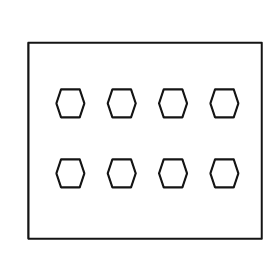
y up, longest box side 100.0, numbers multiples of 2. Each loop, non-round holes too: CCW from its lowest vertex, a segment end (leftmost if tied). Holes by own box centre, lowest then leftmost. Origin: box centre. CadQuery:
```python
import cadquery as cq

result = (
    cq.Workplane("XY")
    .moveTo(-50.0, -42.0)
    .lineTo(50.0, -42.0)
    .lineTo(50.0, 42.0)
    .lineTo(-50.0, 42.0)
    .close()
    .moveTo(-36.0, -20.0)
    .lineTo(-28.0, -20.0)
    .lineTo(-26.0, -14.0)
    .lineTo(-28.0, -8.0)
    .lineTo(-36.0, -8.0)
    .lineTo(-38.0, -14.0)
    .close()
    .moveTo(-14.0, -20.0)
    .lineTo(-6.0, -20.0)
    .lineTo(-4.0, -14.0)
    .lineTo(-6.0, -8.0)
    .lineTo(-14.0, -8.0)
    .lineTo(-16.0, -14.0)
    .close()
    .moveTo(8.0, -20.0)
    .lineTo(16.0, -20.0)
    .lineTo(18.0, -14.0)
    .lineTo(16.0, -8.0)
    .lineTo(8.0, -8.0)
    .lineTo(6.0, -14.0)
    .close()
    .moveTo(30.0, -20.0)
    .lineTo(38.0, -20.0)
    .lineTo(40.0, -14.0)
    .lineTo(38.0, -8.0)
    .lineTo(30.0, -8.0)
    .lineTo(28.0, -14.0)
    .close()
    .moveTo(-36.0, 10.0)
    .lineTo(-28.0, 10.0)
    .lineTo(-26.0, 16.0)
    .lineTo(-28.0, 22.0)
    .lineTo(-36.0, 22.0)
    .lineTo(-38.0, 16.0)
    .close()
    .moveTo(-14.0, 10.0)
    .lineTo(-6.0, 10.0)
    .lineTo(-4.0, 16.0)
    .lineTo(-6.0, 22.0)
    .lineTo(-14.0, 22.0)
    .lineTo(-16.0, 16.0)
    .close()
    .moveTo(8.0, 10.0)
    .lineTo(16.0, 10.0)
    .lineTo(18.0, 16.0)
    .lineTo(16.0, 22.0)
    .lineTo(8.0, 22.0)
    .lineTo(6.0, 16.0)
    .close()
    .moveTo(30.0, 10.0)
    .lineTo(38.0, 10.0)
    .lineTo(40.0, 16.0)
    .lineTo(38.0, 22.0)
    .lineTo(30.0, 22.0)
    .lineTo(28.0, 16.0)
    .close()
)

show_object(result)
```